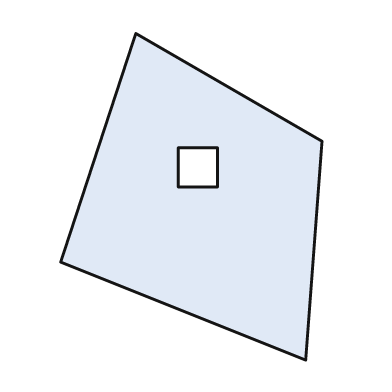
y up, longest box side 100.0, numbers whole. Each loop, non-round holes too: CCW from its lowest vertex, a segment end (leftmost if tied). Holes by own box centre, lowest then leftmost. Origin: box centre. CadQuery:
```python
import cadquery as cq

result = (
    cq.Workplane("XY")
    .moveTo(35.0, -50.0)
    .lineTo(40.0, 17.0)
    .lineTo(-17.0, 50.0)
    .lineTo(-40.0, -20.0)
    .close()
    .moveTo(-4.0, 3.0)
    .lineTo(8.0, 3.0)
    .lineTo(8.0, 15.0)
    .lineTo(-4.0, 15.0)
    .close()
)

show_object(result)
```